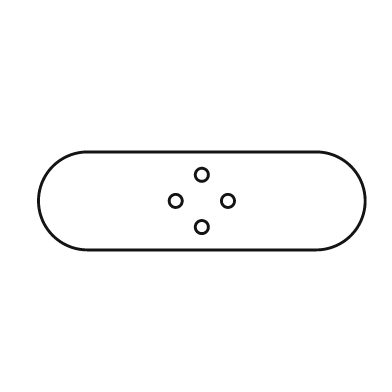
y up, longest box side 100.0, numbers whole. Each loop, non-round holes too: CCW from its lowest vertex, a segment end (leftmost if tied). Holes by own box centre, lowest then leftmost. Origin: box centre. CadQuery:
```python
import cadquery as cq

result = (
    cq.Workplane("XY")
    .moveTo(-35.0, -15.0)
    .lineTo(35.0, -15.0)
    .threePointArc((50.0, 0.0), (35.0, 15.0))
    .lineTo(-35.0, 15.0)
    .threePointArc((-50.0, 0.0), (-35.0, -15.0))
    .close()
    .moveTo(0.0, -8.0)
    .circle(2.0)
    .moveTo(-8.0, 0.0)
    .circle(2.0)
    .moveTo(8.0, 0.0)
    .circle(2.0)
    .moveTo(0.0, 8.0)
    .circle(2.0)
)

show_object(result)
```